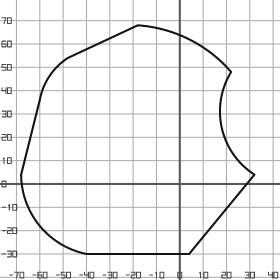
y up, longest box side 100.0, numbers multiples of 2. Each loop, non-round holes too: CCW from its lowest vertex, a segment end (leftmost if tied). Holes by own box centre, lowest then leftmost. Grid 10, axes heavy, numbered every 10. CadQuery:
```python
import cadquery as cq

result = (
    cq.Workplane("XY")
    .moveTo(-40.0, -30.0)
    .lineTo(4.0, -30.0)
    .lineTo(32.0, 4.0)
    .threePointArc((18.0, 24.0), (22.0, 48.0))
    .threePointArc((4.0, 62.0), (-18.0, 68.0))
    .lineTo(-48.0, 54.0)
    .threePointArc((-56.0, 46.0), (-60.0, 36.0))
    .lineTo(-68.0, 4.0)
    .threePointArc((-60.0, -18.0), (-40.0, -30.0))
    .close()
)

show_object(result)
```